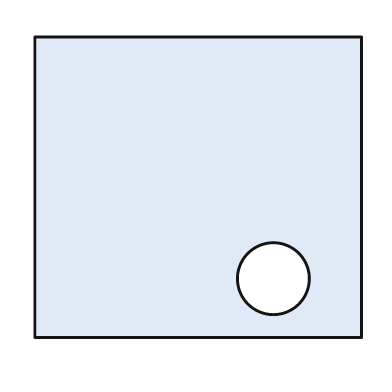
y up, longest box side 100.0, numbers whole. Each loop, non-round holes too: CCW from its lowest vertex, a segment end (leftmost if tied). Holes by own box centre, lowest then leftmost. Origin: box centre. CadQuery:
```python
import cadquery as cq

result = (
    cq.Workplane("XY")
    .moveTo(-50.0, -46.0)
    .lineTo(50.0, -46.0)
    .lineTo(50.0, 46.0)
    .lineTo(-50.0, 46.0)
    .close()
    .moveTo(23.0, -28.0)
    .circle(11.0)
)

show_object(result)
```